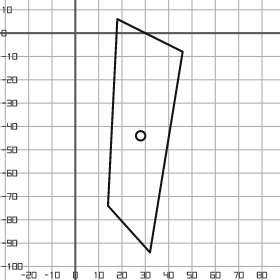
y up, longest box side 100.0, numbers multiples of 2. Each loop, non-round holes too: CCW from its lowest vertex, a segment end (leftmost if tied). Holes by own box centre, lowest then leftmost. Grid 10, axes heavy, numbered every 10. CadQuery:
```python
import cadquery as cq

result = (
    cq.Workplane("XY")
    .moveTo(32.0, -94.0)
    .lineTo(46.0, -8.0)
    .lineTo(18.0, 6.0)
    .lineTo(14.0, -74.0)
    .close()
    .moveTo(28.0, -44.0)
    .circle(2.0)
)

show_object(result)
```